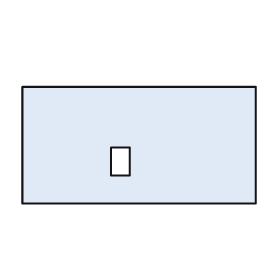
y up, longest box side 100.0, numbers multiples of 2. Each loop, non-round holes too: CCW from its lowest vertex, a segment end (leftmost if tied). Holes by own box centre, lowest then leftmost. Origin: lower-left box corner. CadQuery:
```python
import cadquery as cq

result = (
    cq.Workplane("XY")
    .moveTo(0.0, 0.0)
    .lineTo(100.0, 0.0)
    .lineTo(100.0, 50.0)
    .lineTo(0.0, 50.0)
    .close()
    .moveTo(38.0, 12.0)
    .lineTo(46.0, 12.0)
    .lineTo(46.0, 24.0)
    .lineTo(38.0, 24.0)
    .close()
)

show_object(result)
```